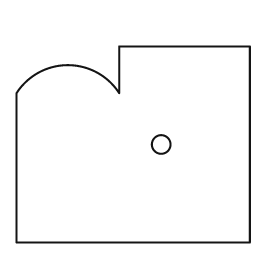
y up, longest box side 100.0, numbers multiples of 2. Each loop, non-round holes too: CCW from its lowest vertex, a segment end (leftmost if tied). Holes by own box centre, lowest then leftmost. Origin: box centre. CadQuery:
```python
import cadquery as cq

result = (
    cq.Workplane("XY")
    .moveTo(-50.0, -42.0)
    .lineTo(50.0, -42.0)
    .lineTo(50.0, 42.0)
    .lineTo(-6.0, 42.0)
    .lineTo(-6.0, 22.0)
    .threePointArc((-28.0, 34.0), (-50.0, 22.0))
    .close()
    .moveTo(12.0, 0.0)
    .circle(4.0)
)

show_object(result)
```